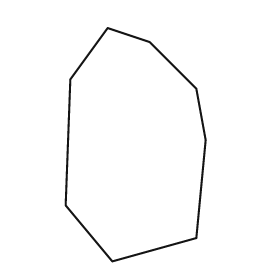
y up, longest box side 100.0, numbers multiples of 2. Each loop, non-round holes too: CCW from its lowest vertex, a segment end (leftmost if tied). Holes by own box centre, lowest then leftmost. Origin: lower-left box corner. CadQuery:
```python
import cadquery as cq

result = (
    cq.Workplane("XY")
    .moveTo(20.0, 0.0)
    .lineTo(56.0, 10.0)
    .lineTo(60.0, 52.0)
    .lineTo(56.0, 74.0)
    .lineTo(36.0, 94.0)
    .lineTo(18.0, 100.0)
    .lineTo(2.0, 78.0)
    .lineTo(0.0, 24.0)
    .close()
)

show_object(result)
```